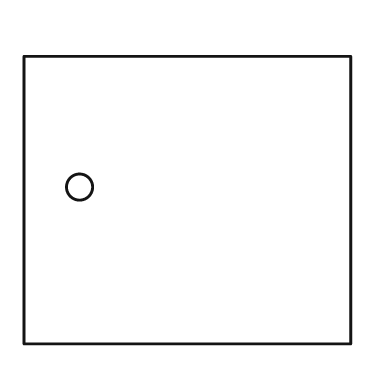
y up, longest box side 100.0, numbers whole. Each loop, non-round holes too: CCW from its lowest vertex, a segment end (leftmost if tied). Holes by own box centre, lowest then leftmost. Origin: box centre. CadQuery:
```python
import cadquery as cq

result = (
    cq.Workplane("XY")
    .moveTo(-50.0, -44.0)
    .lineTo(50.0, -44.0)
    .lineTo(50.0, 44.0)
    .lineTo(-50.0, 44.0)
    .close()
    .moveTo(-33.0, 4.0)
    .circle(4.0)
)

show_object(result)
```